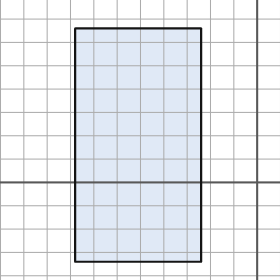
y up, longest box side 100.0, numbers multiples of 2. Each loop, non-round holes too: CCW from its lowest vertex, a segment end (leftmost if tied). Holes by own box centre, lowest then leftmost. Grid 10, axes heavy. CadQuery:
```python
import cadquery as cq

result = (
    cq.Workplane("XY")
    .moveTo(-78.0, -34.0)
    .lineTo(-24.0, -34.0)
    .lineTo(-24.0, 66.0)
    .lineTo(-78.0, 66.0)
    .close()
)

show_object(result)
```